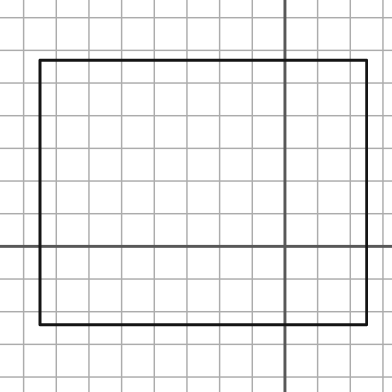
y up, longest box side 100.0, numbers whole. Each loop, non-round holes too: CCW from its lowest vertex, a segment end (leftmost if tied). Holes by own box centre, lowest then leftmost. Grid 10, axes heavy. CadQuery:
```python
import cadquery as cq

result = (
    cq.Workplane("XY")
    .moveTo(-75.0, -24.0)
    .lineTo(25.0, -24.0)
    .lineTo(25.0, 57.0)
    .lineTo(-75.0, 57.0)
    .close()
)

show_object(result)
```